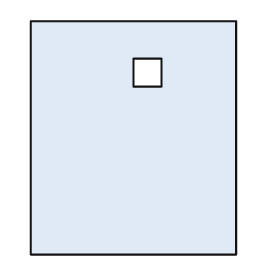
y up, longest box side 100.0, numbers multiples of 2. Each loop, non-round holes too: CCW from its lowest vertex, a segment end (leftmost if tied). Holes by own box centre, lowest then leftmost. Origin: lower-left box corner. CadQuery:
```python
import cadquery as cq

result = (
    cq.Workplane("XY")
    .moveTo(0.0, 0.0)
    .lineTo(88.0, 0.0)
    .lineTo(88.0, 100.0)
    .lineTo(0.0, 100.0)
    .close()
    .moveTo(44.0, 72.0)
    .lineTo(56.0, 72.0)
    .lineTo(56.0, 84.0)
    .lineTo(44.0, 84.0)
    .close()
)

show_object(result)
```